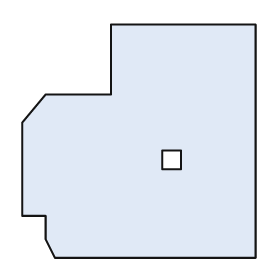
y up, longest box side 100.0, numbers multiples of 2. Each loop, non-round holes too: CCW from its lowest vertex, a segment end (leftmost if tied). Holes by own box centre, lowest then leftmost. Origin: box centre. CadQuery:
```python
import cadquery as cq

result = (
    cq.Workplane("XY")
    .moveTo(-36.0, -50.0)
    .lineTo(50.0, -50.0)
    .lineTo(50.0, 50.0)
    .lineTo(-12.0, 50.0)
    .lineTo(-12.0, 20.0)
    .lineTo(-40.0, 20.0)
    .lineTo(-50.0, 8.0)
    .lineTo(-50.0, -32.0)
    .lineTo(-40.0, -32.0)
    .lineTo(-40.0, -42.0)
    .close()
    .moveTo(10.0, -12.0)
    .lineTo(18.0, -12.0)
    .lineTo(18.0, -4.0)
    .lineTo(10.0, -4.0)
    .close()
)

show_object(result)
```